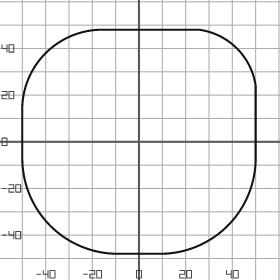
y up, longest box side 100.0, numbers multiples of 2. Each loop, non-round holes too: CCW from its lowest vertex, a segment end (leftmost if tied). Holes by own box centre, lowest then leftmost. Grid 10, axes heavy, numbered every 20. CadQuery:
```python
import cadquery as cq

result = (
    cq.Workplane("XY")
    .moveTo(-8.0, -48.0)
    .lineTo(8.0, -48.0)
    .threePointArc((38.0, -36.0), (50.0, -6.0))
    .lineTo(50.0, 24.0)
    .threePointArc((42.0, 40.0), (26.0, 48.0))
    .lineTo(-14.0, 48.0)
    .threePointArc((-40.0, 38.0), (-50.0, 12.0))
    .lineTo(-50.0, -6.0)
    .threePointArc((-38.0, -36.0), (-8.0, -48.0))
    .close()
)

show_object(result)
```